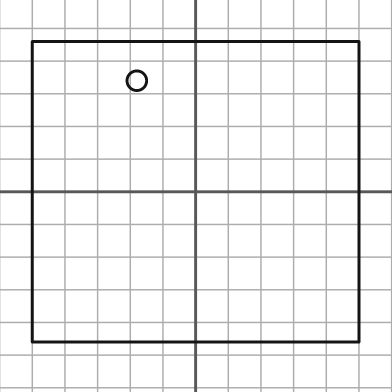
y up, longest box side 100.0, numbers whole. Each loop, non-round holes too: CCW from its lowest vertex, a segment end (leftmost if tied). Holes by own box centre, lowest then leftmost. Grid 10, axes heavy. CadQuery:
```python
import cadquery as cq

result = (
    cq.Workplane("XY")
    .moveTo(-50.0, -46.0)
    .lineTo(50.0, -46.0)
    .lineTo(50.0, 46.0)
    .lineTo(-50.0, 46.0)
    .close()
    .moveTo(-18.0, 34.0)
    .circle(3.0)
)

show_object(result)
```